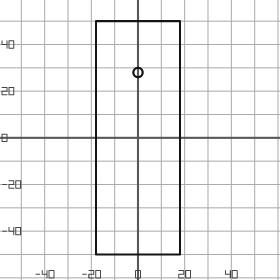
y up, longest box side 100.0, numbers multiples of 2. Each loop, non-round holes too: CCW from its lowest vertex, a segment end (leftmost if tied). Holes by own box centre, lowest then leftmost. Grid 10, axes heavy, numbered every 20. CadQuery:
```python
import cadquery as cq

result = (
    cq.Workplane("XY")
    .moveTo(-18.0, -50.0)
    .lineTo(18.0, -50.0)
    .lineTo(18.0, 50.0)
    .lineTo(-18.0, 50.0)
    .close()
    .moveTo(0.0, 28.0)
    .circle(2.0)
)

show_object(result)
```